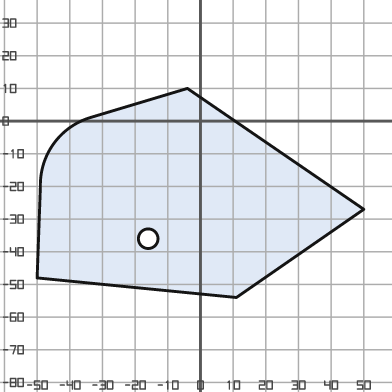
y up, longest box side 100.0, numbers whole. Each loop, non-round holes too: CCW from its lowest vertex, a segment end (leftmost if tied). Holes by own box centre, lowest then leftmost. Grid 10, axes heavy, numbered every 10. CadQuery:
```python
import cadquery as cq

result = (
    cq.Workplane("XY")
    .moveTo(11.0, -54.0)
    .lineTo(50.0, -27.0)
    .lineTo(-4.0, 10.0)
    .lineTo(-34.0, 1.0)
    .threePointArc((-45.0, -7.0), (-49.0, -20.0))
    .lineTo(-50.0, -48.0)
    .close()
    .moveTo(-16.0, -36.0)
    .circle(3.0)
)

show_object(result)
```